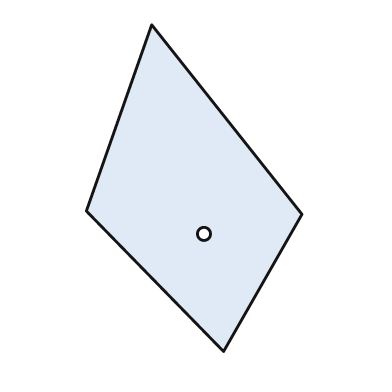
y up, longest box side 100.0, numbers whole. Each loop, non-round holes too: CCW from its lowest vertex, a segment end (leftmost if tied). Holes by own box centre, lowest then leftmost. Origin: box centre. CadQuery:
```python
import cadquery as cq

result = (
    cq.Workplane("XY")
    .moveTo(9.0, -50.0)
    .lineTo(33.0, -8.0)
    .lineTo(-13.0, 50.0)
    .lineTo(-33.0, -7.0)
    .close()
    .moveTo(3.0, -14.0)
    .circle(2.0)
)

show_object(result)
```